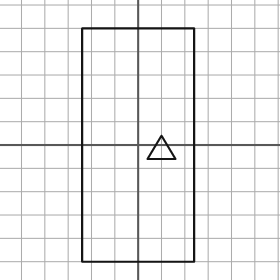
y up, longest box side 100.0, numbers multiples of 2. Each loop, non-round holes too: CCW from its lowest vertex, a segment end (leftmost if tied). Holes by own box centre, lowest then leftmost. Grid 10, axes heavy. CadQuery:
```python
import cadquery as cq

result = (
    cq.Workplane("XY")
    .moveTo(-24.0, -50.0)
    .lineTo(24.0, -50.0)
    .lineTo(24.0, 50.0)
    .lineTo(-24.0, 50.0)
    .close()
    .moveTo(4.0, -6.0)
    .lineTo(16.0, -6.0)
    .lineTo(10.0, 4.0)
    .close()
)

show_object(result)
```